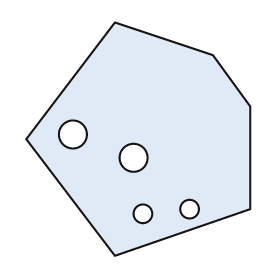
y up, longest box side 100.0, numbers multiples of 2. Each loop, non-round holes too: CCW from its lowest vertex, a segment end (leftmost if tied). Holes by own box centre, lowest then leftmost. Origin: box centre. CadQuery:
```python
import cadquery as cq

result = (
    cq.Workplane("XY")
    .moveTo(-10.0, -50.0)
    .lineTo(48.0, -30.0)
    .lineTo(48.0, 14.0)
    .lineTo(32.0, 36.0)
    .lineTo(-10.0, 50.0)
    .lineTo(-48.0, 0.0)
    .close()
    .moveTo(2.0, -32.0)
    .circle(4.0)
    .moveTo(22.0, -30.0)
    .circle(4.0)
    .moveTo(-2.0, -8.0)
    .circle(6.0)
    .moveTo(-28.0, 2.0)
    .circle(6.0)
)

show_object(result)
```